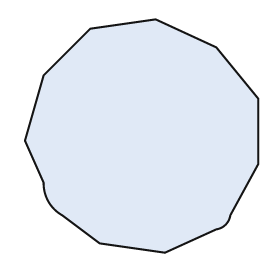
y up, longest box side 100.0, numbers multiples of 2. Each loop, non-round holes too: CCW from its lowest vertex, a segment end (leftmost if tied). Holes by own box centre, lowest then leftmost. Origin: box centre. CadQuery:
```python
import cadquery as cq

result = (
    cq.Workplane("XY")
    .moveTo(10.0, -50.0)
    .lineTo(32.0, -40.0)
    .threePointArc((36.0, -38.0), (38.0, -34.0))
    .lineTo(50.0, -12.0)
    .lineTo(50.0, 16.0)
    .lineTo(32.0, 38.0)
    .lineTo(6.0, 50.0)
    .lineTo(-22.0, 46.0)
    .lineTo(-42.0, 26.0)
    .lineTo(-50.0, -2.0)
    .lineTo(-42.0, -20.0)
    .threePointArc((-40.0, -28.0), (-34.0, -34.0))
    .lineTo(-18.0, -46.0)
    .close()
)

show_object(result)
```